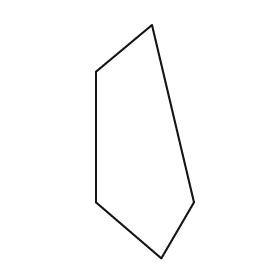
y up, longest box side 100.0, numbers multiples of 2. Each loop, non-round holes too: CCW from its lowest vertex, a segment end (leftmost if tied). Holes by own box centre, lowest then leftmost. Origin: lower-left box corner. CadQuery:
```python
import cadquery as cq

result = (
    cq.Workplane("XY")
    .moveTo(28.0, 0.0)
    .lineTo(42.0, 24.0)
    .lineTo(24.0, 100.0)
    .lineTo(0.0, 80.0)
    .lineTo(0.0, 24.0)
    .close()
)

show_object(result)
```